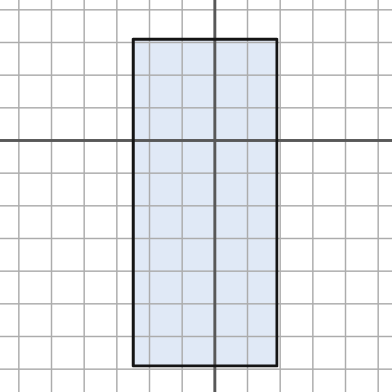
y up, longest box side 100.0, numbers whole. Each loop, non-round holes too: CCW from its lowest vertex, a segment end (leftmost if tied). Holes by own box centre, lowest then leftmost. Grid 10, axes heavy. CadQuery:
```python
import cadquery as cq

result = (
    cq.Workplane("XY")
    .moveTo(-25.0, -69.0)
    .lineTo(19.0, -69.0)
    .lineTo(19.0, 31.0)
    .lineTo(-25.0, 31.0)
    .close()
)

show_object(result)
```